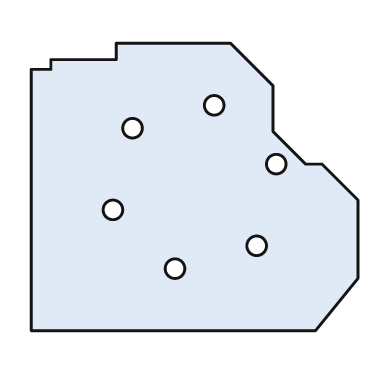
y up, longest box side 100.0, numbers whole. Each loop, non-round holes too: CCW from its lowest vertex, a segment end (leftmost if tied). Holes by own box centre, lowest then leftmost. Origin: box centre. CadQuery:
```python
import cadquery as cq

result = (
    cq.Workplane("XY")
    .moveTo(-50.0, -44.0)
    .lineTo(37.0, -44.0)
    .lineTo(50.0, -28.0)
    .lineTo(50.0, -4.0)
    .lineTo(39.0, 7.0)
    .lineTo(34.0, 7.0)
    .lineTo(24.0, 17.0)
    .lineTo(24.0, 31.0)
    .lineTo(11.0, 44.0)
    .lineTo(-24.0, 44.0)
    .lineTo(-24.0, 39.0)
    .lineTo(-44.0, 39.0)
    .lineTo(-44.0, 36.0)
    .lineTo(-50.0, 36.0)
    .close()
    .moveTo(-6.0, -25.0)
    .circle(3.0)
    .moveTo(19.0, -18.0)
    .circle(3.0)
    .moveTo(-25.0, -7.0)
    .circle(3.0)
    .moveTo(25.0, 7.0)
    .circle(3.0)
    .moveTo(-19.0, 18.0)
    .circle(3.0)
    .moveTo(6.0, 25.0)
    .circle(3.0)
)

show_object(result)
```